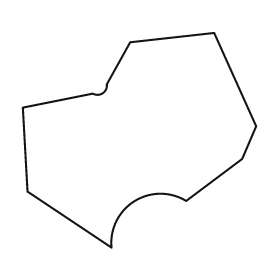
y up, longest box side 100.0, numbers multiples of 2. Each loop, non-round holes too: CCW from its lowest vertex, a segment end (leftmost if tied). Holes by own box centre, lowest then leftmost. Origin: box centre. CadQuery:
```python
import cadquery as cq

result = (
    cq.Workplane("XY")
    .moveTo(-12.0, -46.0)
    .threePointArc((-2.0, -26.0), (20.0, -26.0))
    .lineTo(44.0, -8.0)
    .lineTo(50.0, 6.0)
    .lineTo(32.0, 46.0)
    .lineTo(-4.0, 42.0)
    .lineTo(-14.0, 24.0)
    .threePointArc((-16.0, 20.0), (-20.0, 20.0))
    .lineTo(-50.0, 14.0)
    .lineTo(-48.0, -22.0)
    .close()
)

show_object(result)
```